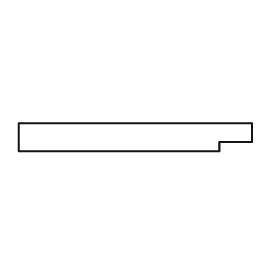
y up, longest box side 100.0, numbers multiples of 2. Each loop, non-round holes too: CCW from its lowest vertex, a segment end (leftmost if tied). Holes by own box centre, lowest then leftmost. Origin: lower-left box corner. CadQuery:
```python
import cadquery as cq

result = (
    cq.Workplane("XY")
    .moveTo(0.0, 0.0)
    .lineTo(86.0, 0.0)
    .lineTo(86.0, 4.0)
    .lineTo(100.0, 4.0)
    .lineTo(100.0, 12.0)
    .lineTo(0.0, 12.0)
    .close()
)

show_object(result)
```